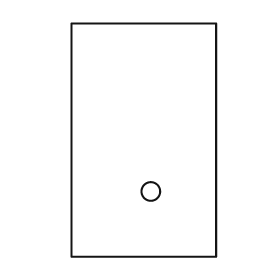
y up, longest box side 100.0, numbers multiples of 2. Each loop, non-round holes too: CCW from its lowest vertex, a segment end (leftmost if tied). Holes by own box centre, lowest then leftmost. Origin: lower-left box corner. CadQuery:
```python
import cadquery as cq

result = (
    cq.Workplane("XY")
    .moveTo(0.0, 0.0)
    .lineTo(62.0, 0.0)
    .lineTo(62.0, 100.0)
    .lineTo(0.0, 100.0)
    .close()
    .moveTo(34.0, 28.0)
    .circle(4.0)
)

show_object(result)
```